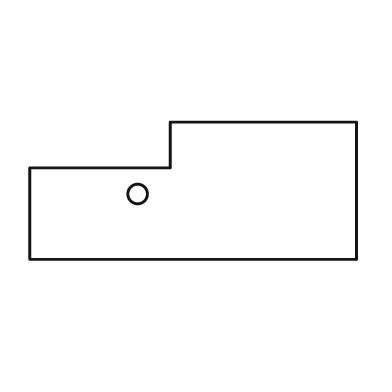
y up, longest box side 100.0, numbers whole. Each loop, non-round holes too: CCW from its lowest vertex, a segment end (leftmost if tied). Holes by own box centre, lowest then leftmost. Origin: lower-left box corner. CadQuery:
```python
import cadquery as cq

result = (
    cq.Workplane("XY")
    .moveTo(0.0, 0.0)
    .lineTo(100.0, 0.0)
    .lineTo(100.0, 42.0)
    .lineTo(43.0, 42.0)
    .lineTo(43.0, 28.0)
    .lineTo(0.0, 28.0)
    .close()
    .moveTo(33.0, 20.0)
    .circle(3.0)
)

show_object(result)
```